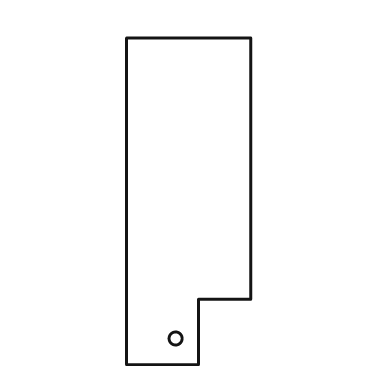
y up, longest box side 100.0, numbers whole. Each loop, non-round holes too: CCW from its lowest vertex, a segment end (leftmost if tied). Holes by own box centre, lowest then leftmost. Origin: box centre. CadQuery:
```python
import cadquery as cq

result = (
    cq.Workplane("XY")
    .moveTo(-19.0, -50.0)
    .lineTo(3.0, -50.0)
    .lineTo(3.0, -30.0)
    .lineTo(19.0, -30.0)
    .lineTo(19.0, 50.0)
    .lineTo(-19.0, 50.0)
    .close()
    .moveTo(-4.0, -42.0)
    .circle(2.0)
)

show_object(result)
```